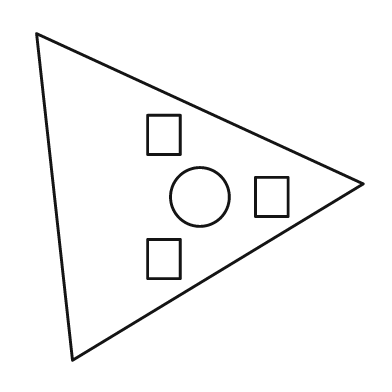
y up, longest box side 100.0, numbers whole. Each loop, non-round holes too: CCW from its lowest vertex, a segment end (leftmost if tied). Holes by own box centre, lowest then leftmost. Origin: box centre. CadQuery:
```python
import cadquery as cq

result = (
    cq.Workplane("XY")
    .moveTo(-39.0, -50.0)
    .lineTo(50.0, 4.0)
    .lineTo(-50.0, 50.0)
    .close()
    .moveTo(-16.0, -25.0)
    .lineTo(-6.0, -25.0)
    .lineTo(-6.0, -13.0)
    .lineTo(-16.0, -13.0)
    .close()
    .moveTo(0.0, 0.0)
    .circle(9.0)
    .moveTo(17.0, -6.0)
    .lineTo(27.0, -6.0)
    .lineTo(27.0, 6.0)
    .lineTo(17.0, 6.0)
    .close()
    .moveTo(-16.0, 13.0)
    .lineTo(-6.0, 13.0)
    .lineTo(-6.0, 25.0)
    .lineTo(-16.0, 25.0)
    .close()
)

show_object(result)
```